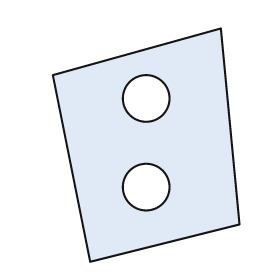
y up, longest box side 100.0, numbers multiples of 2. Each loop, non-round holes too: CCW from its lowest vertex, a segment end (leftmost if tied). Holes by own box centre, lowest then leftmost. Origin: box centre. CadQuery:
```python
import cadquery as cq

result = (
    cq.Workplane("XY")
    .moveTo(-24.0, -50.0)
    .lineTo(40.0, -34.0)
    .lineTo(32.0, 50.0)
    .lineTo(-40.0, 30.0)
    .close()
    .moveTo(0.0, -18.0)
    .circle(10.0)
    .moveTo(0.0, 20.0)
    .circle(10.0)
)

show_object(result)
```